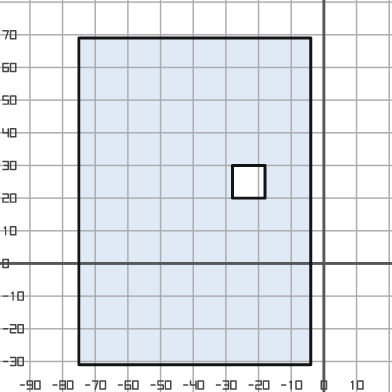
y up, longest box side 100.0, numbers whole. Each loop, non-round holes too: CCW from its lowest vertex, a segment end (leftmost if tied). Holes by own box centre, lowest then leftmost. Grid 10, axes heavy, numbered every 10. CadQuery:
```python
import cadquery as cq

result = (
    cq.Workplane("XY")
    .moveTo(-75.0, -31.0)
    .lineTo(-4.0, -31.0)
    .lineTo(-4.0, 69.0)
    .lineTo(-75.0, 69.0)
    .close()
    .moveTo(-28.0, 20.0)
    .lineTo(-18.0, 20.0)
    .lineTo(-18.0, 30.0)
    .lineTo(-28.0, 30.0)
    .close()
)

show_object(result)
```